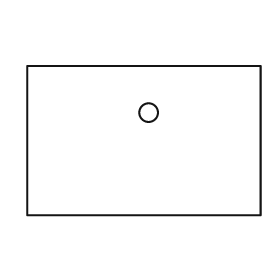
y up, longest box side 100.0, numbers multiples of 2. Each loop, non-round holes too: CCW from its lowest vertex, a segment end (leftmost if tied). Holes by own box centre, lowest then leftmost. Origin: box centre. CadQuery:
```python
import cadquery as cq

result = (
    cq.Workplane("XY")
    .moveTo(-50.0, -32.0)
    .lineTo(50.0, -32.0)
    .lineTo(50.0, 32.0)
    .lineTo(-50.0, 32.0)
    .close()
    .moveTo(2.0, 12.0)
    .circle(4.0)
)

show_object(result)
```